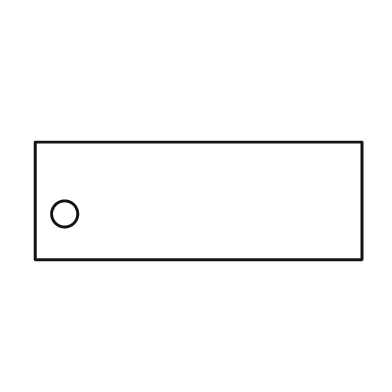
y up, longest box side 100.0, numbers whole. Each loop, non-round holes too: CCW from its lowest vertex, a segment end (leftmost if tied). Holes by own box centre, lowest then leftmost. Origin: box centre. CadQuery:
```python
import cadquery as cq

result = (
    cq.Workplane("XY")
    .moveTo(-50.0, -18.0)
    .lineTo(50.0, -18.0)
    .lineTo(50.0, 18.0)
    .lineTo(-50.0, 18.0)
    .close()
    .moveTo(-41.0, -4.0)
    .circle(4.0)
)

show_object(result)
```